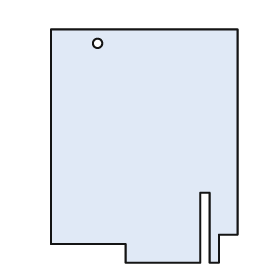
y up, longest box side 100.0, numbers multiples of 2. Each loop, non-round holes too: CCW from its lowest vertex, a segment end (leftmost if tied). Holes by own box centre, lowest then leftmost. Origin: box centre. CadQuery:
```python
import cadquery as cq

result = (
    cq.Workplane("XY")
    .moveTo(-8.0, -50.0)
    .lineTo(24.0, -50.0)
    .lineTo(24.0, -20.0)
    .lineTo(28.0, -20.0)
    .lineTo(28.0, -50.0)
    .lineTo(32.0, -50.0)
    .lineTo(32.0, -38.0)
    .lineTo(40.0, -38.0)
    .lineTo(40.0, 50.0)
    .lineTo(-40.0, 50.0)
    .lineTo(-40.0, -42.0)
    .lineTo(-8.0, -42.0)
    .close()
    .moveTo(-20.0, 44.0)
    .circle(2.0)
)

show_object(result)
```